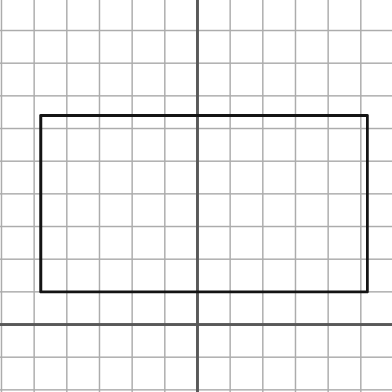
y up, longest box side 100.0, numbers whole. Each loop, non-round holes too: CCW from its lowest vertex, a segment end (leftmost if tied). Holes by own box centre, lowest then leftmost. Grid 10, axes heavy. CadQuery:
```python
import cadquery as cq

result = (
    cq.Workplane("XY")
    .moveTo(-48.0, 10.0)
    .lineTo(52.0, 10.0)
    .lineTo(52.0, 64.0)
    .lineTo(-48.0, 64.0)
    .close()
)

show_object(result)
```